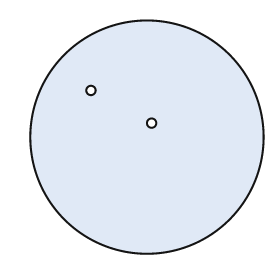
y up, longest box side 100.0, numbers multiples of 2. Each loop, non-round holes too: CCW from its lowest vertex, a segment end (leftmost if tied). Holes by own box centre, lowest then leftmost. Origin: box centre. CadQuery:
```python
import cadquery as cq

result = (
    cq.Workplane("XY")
    .moveTo(0.0, 0.0)
    .circle(50.0)
    .moveTo(2.0, 6.0)
    .circle(2.0)
    .moveTo(-24.0, 20.0)
    .circle(2.0)
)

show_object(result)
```